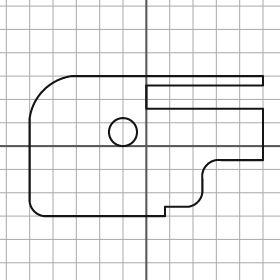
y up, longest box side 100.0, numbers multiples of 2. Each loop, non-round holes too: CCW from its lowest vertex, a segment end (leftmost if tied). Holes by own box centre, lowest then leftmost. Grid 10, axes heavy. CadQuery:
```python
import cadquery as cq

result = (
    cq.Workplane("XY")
    .moveTo(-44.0, -30.0)
    .lineTo(8.0, -30.0)
    .lineTo(8.0, -26.0)
    .lineTo(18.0, -26.0)
    .threePointArc((22.0, -24.0), (24.0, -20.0))
    .lineTo(24.0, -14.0)
    .threePointArc((26.0, -8.0), (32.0, -6.0))
    .lineTo(50.0, -6.0)
    .lineTo(50.0, 16.0)
    .lineTo(0.0, 16.0)
    .lineTo(0.0, 26.0)
    .lineTo(50.0, 26.0)
    .lineTo(50.0, 30.0)
    .lineTo(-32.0, 30.0)
    .threePointArc((-44.0, 24.0), (-50.0, 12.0))
    .lineTo(-50.0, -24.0)
    .threePointArc((-48.0, -28.0), (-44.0, -30.0))
    .close()
    .moveTo(-10.0, 6.0)
    .circle(6.0)
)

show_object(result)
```